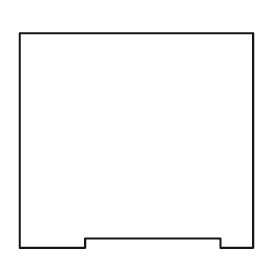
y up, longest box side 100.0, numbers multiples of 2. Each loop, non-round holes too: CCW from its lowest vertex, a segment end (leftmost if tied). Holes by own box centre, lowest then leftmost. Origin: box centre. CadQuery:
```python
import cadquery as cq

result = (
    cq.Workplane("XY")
    .moveTo(-50.0, -46.0)
    .lineTo(-22.0, -46.0)
    .lineTo(-22.0, -42.0)
    .lineTo(36.0, -42.0)
    .lineTo(36.0, -46.0)
    .lineTo(50.0, -46.0)
    .lineTo(50.0, 46.0)
    .lineTo(-50.0, 46.0)
    .close()
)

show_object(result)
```